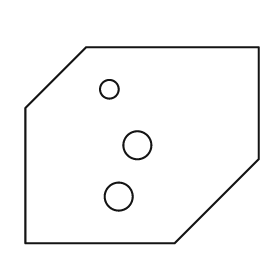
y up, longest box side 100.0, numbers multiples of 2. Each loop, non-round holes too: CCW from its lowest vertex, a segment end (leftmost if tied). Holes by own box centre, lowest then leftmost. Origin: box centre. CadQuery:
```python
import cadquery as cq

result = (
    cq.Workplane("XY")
    .moveTo(-50.0, -42.0)
    .lineTo(14.0, -42.0)
    .lineTo(50.0, -6.0)
    .lineTo(50.0, 42.0)
    .lineTo(-24.0, 42.0)
    .lineTo(-50.0, 16.0)
    .close()
    .moveTo(-10.0, -22.0)
    .circle(6.0)
    .moveTo(-2.0, 0.0)
    .circle(6.0)
    .moveTo(-14.0, 24.0)
    .circle(4.0)
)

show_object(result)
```